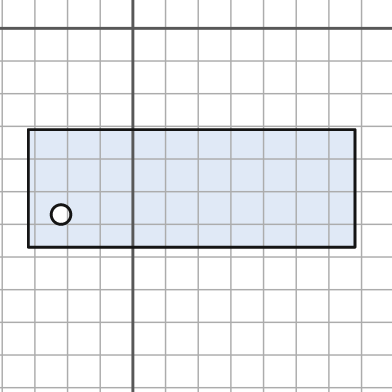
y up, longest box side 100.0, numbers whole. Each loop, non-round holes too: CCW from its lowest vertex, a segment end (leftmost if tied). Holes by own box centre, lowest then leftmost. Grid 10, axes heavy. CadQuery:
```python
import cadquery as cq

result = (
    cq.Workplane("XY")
    .moveTo(-32.0, -67.0)
    .lineTo(68.0, -67.0)
    .lineTo(68.0, -31.0)
    .lineTo(-32.0, -31.0)
    .close()
    .moveTo(-22.0, -57.0)
    .circle(3.0)
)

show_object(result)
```